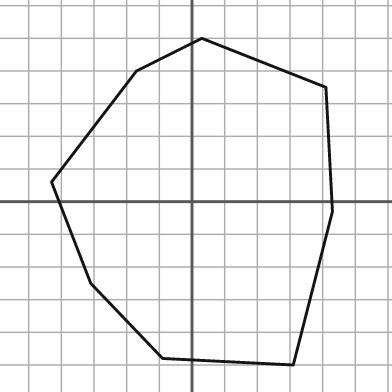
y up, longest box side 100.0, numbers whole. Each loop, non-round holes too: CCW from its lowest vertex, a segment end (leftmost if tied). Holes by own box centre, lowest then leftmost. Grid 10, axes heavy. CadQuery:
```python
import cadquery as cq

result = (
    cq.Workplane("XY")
    .moveTo(31.0, -50.0)
    .lineTo(43.0, -3.0)
    .lineTo(41.0, 35.0)
    .lineTo(3.0, 50.0)
    .lineTo(-17.0, 40.0)
    .lineTo(-43.0, 6.0)
    .lineTo(-31.0, -25.0)
    .lineTo(-9.0, -48.0)
    .close()
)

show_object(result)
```